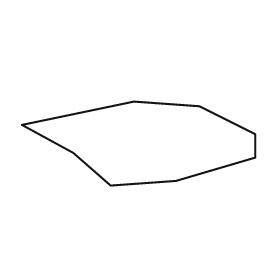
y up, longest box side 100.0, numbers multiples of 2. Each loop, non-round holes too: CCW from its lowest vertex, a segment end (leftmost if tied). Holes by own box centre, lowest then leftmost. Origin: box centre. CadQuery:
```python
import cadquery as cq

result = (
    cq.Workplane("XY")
    .moveTo(-12.0, -18.0)
    .lineTo(16.0, -16.0)
    .lineTo(50.0, -6.0)
    .lineTo(50.0, 4.0)
    .lineTo(26.0, 16.0)
    .lineTo(-2.0, 18.0)
    .lineTo(-50.0, 8.0)
    .lineTo(-28.0, -4.0)
    .close()
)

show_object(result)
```